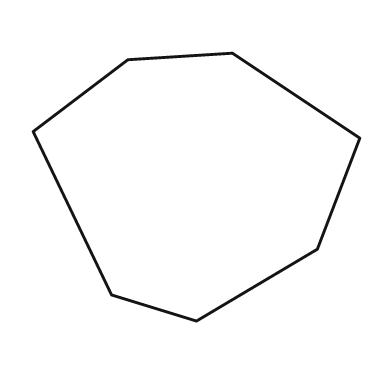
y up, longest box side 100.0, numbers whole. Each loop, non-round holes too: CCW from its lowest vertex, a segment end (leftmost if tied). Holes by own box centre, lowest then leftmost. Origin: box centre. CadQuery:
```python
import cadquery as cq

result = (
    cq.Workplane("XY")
    .moveTo(0.0, -41.0)
    .lineTo(37.0, -19.0)
    .lineTo(50.0, 15.0)
    .lineTo(11.0, 41.0)
    .lineTo(-21.0, 39.0)
    .lineTo(-50.0, 17.0)
    .lineTo(-26.0, -33.0)
    .close()
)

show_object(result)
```